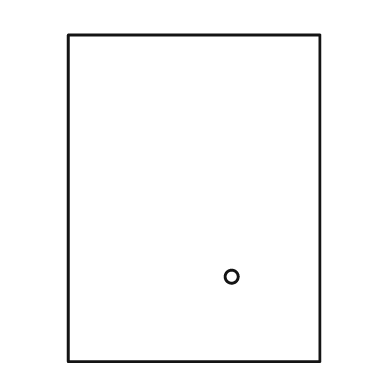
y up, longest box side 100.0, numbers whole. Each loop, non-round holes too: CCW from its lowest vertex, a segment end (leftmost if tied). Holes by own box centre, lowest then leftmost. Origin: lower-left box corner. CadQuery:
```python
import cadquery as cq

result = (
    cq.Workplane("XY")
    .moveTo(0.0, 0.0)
    .lineTo(77.0, 0.0)
    .lineTo(77.0, 100.0)
    .lineTo(0.0, 100.0)
    .close()
    .moveTo(50.0, 26.0)
    .circle(2.0)
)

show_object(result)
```